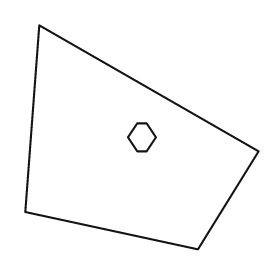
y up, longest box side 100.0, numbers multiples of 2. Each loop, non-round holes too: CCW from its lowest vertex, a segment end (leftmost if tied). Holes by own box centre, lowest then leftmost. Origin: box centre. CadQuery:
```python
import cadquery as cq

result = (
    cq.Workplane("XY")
    .moveTo(24.0, -48.0)
    .lineTo(50.0, -6.0)
    .lineTo(-44.0, 48.0)
    .lineTo(-50.0, -32.0)
    .close()
    .moveTo(-2.0, -6.0)
    .lineTo(2.0, -6.0)
    .lineTo(6.0, 0.0)
    .lineTo(2.0, 6.0)
    .lineTo(-2.0, 6.0)
    .lineTo(-6.0, 0.0)
    .close()
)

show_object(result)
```